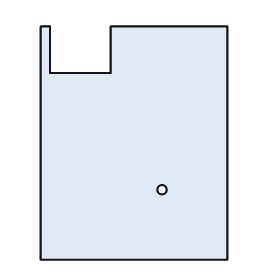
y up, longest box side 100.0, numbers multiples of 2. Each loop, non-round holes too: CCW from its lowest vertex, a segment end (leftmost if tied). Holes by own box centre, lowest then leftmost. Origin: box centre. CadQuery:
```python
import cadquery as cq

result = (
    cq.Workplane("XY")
    .moveTo(-40.0, -50.0)
    .lineTo(40.0, -50.0)
    .lineTo(40.0, 50.0)
    .lineTo(-10.0, 50.0)
    .lineTo(-10.0, 30.0)
    .lineTo(-36.0, 30.0)
    .lineTo(-36.0, 50.0)
    .lineTo(-40.0, 50.0)
    .close()
    .moveTo(12.0, -20.0)
    .circle(2.0)
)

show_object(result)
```